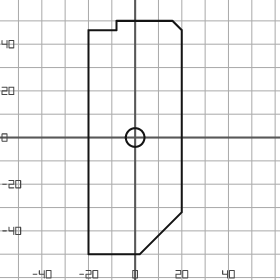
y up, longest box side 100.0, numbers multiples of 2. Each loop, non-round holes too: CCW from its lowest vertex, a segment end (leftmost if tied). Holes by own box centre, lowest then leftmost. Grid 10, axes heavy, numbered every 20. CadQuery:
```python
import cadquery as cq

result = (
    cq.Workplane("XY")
    .moveTo(-20.0, -50.0)
    .lineTo(2.0, -50.0)
    .lineTo(20.0, -32.0)
    .lineTo(20.0, 46.0)
    .lineTo(16.0, 50.0)
    .lineTo(-8.0, 50.0)
    .lineTo(-8.0, 46.0)
    .lineTo(-20.0, 46.0)
    .close()
    .moveTo(0.0, 0.0)
    .circle(4.0)
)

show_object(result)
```